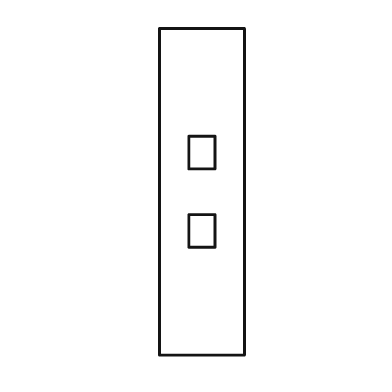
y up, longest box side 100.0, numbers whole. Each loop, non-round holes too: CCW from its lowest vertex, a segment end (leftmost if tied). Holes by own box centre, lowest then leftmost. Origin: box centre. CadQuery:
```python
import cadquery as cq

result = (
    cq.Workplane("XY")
    .moveTo(-13.0, -50.0)
    .lineTo(13.0, -50.0)
    .lineTo(13.0, 50.0)
    .lineTo(-13.0, 50.0)
    .close()
    .moveTo(-4.0, -17.0)
    .lineTo(4.0, -17.0)
    .lineTo(4.0, -7.0)
    .lineTo(-4.0, -7.0)
    .close()
    .moveTo(-4.0, 7.0)
    .lineTo(4.0, 7.0)
    .lineTo(4.0, 17.0)
    .lineTo(-4.0, 17.0)
    .close()
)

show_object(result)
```